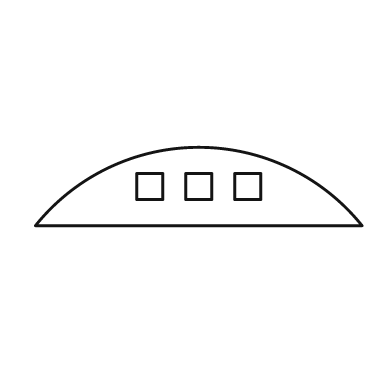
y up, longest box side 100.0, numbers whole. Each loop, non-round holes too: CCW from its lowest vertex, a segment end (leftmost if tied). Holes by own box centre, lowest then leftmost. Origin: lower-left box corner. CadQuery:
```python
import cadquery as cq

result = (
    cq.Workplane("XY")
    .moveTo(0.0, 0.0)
    .lineTo(100.0, 0.0)
    .threePointArc((50.0, 24.0), (0.0, 0.0))
    .close()
    .moveTo(31.0, 8.0)
    .lineTo(39.0, 8.0)
    .lineTo(39.0, 16.0)
    .lineTo(31.0, 16.0)
    .close()
    .moveTo(46.0, 8.0)
    .lineTo(54.0, 8.0)
    .lineTo(54.0, 16.0)
    .lineTo(46.0, 16.0)
    .close()
    .moveTo(61.0, 8.0)
    .lineTo(69.0, 8.0)
    .lineTo(69.0, 16.0)
    .lineTo(61.0, 16.0)
    .close()
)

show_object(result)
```